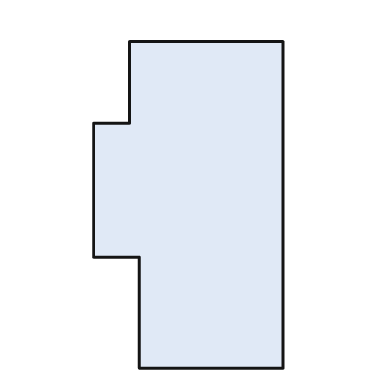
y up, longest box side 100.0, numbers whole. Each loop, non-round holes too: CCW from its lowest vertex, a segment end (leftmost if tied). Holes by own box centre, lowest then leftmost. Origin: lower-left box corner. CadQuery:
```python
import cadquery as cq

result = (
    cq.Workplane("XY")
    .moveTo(14.0, 0.0)
    .lineTo(58.0, 0.0)
    .lineTo(58.0, 100.0)
    .lineTo(11.0, 100.0)
    .lineTo(11.0, 75.0)
    .lineTo(0.0, 75.0)
    .lineTo(0.0, 34.0)
    .lineTo(14.0, 34.0)
    .close()
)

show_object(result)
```